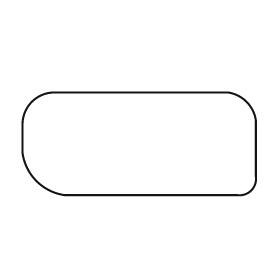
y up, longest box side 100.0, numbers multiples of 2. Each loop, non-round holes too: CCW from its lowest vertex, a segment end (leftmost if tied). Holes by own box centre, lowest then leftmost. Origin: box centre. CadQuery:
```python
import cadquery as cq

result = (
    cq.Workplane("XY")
    .moveTo(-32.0, -22.0)
    .lineTo(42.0, -22.0)
    .threePointArc((48.0, -20.0), (50.0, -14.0))
    .lineTo(50.0, 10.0)
    .threePointArc((46.0, 18.0), (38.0, 22.0))
    .lineTo(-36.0, 22.0)
    .threePointArc((-46.0, 18.0), (-50.0, 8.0))
    .lineTo(-50.0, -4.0)
    .threePointArc((-44.0, -16.0), (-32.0, -22.0))
    .close()
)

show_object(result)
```